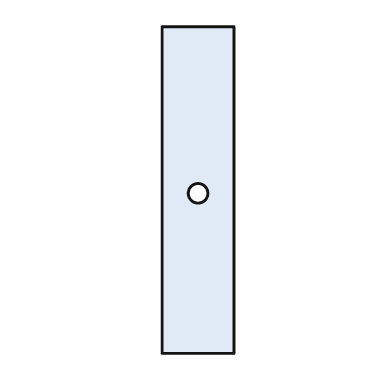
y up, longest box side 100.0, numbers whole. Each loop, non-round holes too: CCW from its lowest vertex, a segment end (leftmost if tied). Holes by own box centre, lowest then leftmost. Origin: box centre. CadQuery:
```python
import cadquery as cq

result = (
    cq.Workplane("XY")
    .moveTo(-11.0, -50.0)
    .lineTo(11.0, -50.0)
    .lineTo(11.0, 50.0)
    .lineTo(-11.0, 50.0)
    .close()
    .moveTo(0.0, -1.0)
    .circle(3.0)
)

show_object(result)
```